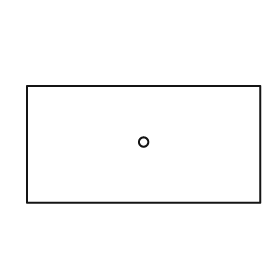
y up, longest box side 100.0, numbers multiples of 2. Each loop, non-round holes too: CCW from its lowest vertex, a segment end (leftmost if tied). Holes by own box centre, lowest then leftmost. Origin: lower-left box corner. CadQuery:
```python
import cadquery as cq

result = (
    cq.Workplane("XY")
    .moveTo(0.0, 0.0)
    .lineTo(100.0, 0.0)
    .lineTo(100.0, 50.0)
    .lineTo(0.0, 50.0)
    .close()
    .moveTo(50.0, 26.0)
    .circle(2.0)
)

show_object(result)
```